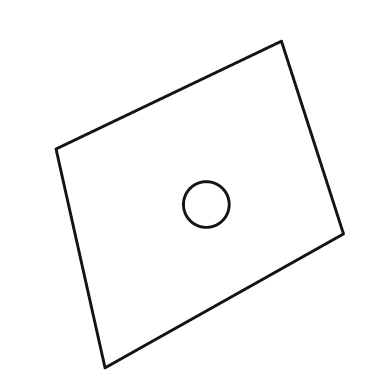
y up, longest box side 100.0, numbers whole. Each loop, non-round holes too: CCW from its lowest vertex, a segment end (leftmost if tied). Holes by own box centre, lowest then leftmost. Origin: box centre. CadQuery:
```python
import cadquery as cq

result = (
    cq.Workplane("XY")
    .moveTo(-29.0, -50.0)
    .lineTo(44.0, -9.0)
    .lineTo(25.0, 50.0)
    .lineTo(-44.0, 17.0)
    .close()
    .moveTo(2.0, 0.0)
    .circle(7.0)
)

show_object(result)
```